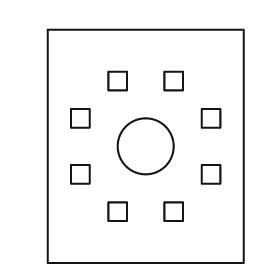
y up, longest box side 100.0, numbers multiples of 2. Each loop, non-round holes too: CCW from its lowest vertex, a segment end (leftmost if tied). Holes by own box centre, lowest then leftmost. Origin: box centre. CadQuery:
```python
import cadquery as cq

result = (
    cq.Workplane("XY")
    .moveTo(-42.0, -50.0)
    .lineTo(42.0, -50.0)
    .lineTo(42.0, 50.0)
    .lineTo(-42.0, 50.0)
    .close()
    .moveTo(-16.0, -32.0)
    .lineTo(-8.0, -32.0)
    .lineTo(-8.0, -24.0)
    .lineTo(-16.0, -24.0)
    .close()
    .moveTo(8.0, -32.0)
    .lineTo(16.0, -32.0)
    .lineTo(16.0, -24.0)
    .lineTo(8.0, -24.0)
    .close()
    .moveTo(-32.0, -16.0)
    .lineTo(-24.0, -16.0)
    .lineTo(-24.0, -8.0)
    .lineTo(-32.0, -8.0)
    .close()
    .moveTo(24.0, -16.0)
    .lineTo(32.0, -16.0)
    .lineTo(32.0, -8.0)
    .lineTo(24.0, -8.0)
    .close()
    .moveTo(0.0, 0.0)
    .circle(12.0)
    .moveTo(-32.0, 8.0)
    .lineTo(-24.0, 8.0)
    .lineTo(-24.0, 16.0)
    .lineTo(-32.0, 16.0)
    .close()
    .moveTo(24.0, 8.0)
    .lineTo(32.0, 8.0)
    .lineTo(32.0, 16.0)
    .lineTo(24.0, 16.0)
    .close()
    .moveTo(-16.0, 24.0)
    .lineTo(-8.0, 24.0)
    .lineTo(-8.0, 32.0)
    .lineTo(-16.0, 32.0)
    .close()
    .moveTo(8.0, 24.0)
    .lineTo(16.0, 24.0)
    .lineTo(16.0, 32.0)
    .lineTo(8.0, 32.0)
    .close()
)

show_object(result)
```